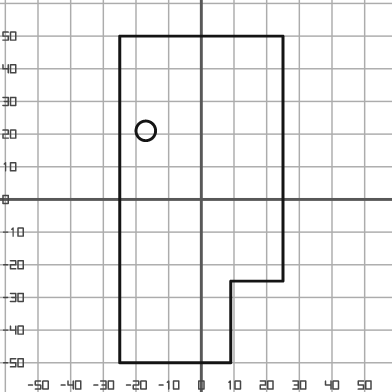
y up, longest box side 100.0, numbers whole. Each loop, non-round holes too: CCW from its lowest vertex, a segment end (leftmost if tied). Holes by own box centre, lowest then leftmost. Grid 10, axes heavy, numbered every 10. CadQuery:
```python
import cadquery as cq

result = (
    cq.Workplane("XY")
    .moveTo(-25.0, -50.0)
    .lineTo(9.0, -50.0)
    .lineTo(9.0, -25.0)
    .lineTo(25.0, -25.0)
    .lineTo(25.0, 50.0)
    .lineTo(-25.0, 50.0)
    .close()
    .moveTo(-17.0, 21.0)
    .circle(3.0)
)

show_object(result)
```